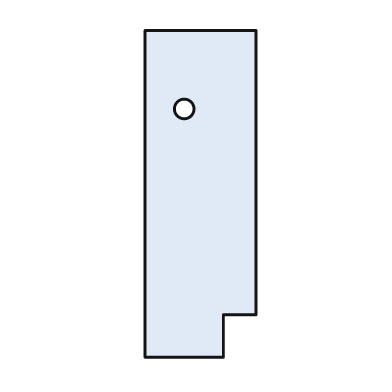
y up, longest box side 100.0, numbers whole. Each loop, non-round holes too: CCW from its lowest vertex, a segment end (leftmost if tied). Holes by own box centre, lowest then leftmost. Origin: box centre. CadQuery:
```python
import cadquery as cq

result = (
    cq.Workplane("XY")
    .moveTo(-17.0, -50.0)
    .lineTo(7.0, -50.0)
    .lineTo(7.0, -37.0)
    .lineTo(17.0, -37.0)
    .lineTo(17.0, 50.0)
    .lineTo(-17.0, 50.0)
    .close()
    .moveTo(-5.0, 26.0)
    .circle(3.0)
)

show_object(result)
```